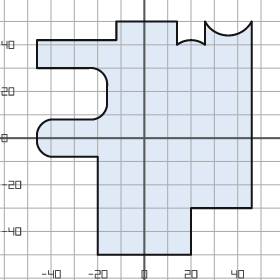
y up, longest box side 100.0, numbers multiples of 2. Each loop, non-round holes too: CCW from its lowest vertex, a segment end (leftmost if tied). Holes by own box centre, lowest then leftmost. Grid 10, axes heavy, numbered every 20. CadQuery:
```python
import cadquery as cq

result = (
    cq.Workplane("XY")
    .moveTo(-20.0, -50.0)
    .lineTo(20.0, -50.0)
    .lineTo(20.0, -30.0)
    .lineTo(46.0, -30.0)
    .lineTo(46.0, 50.0)
    .threePointArc((36.0, 44.0), (26.0, 50.0))
    .lineTo(26.0, 40.0)
    .threePointArc((20.0, 42.0), (14.0, 40.0))
    .lineTo(14.0, 50.0)
    .lineTo(-12.0, 50.0)
    .lineTo(-12.0, 42.0)
    .lineTo(-46.0, 42.0)
    .lineTo(-46.0, 30.0)
    .lineTo(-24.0, 30.0)
    .threePointArc((-18.0, 28.0), (-16.0, 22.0))
    .lineTo(-16.0, 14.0)
    .threePointArc((-18.0, 10.0), (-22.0, 8.0))
    .lineTo(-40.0, 8.0)
    .threePointArc((-44.0, 6.0), (-46.0, 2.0))
    .lineTo(-46.0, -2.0)
    .threePointArc((-44.0, -6.0), (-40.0, -8.0))
    .lineTo(-20.0, -8.0)
    .close()
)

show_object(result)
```